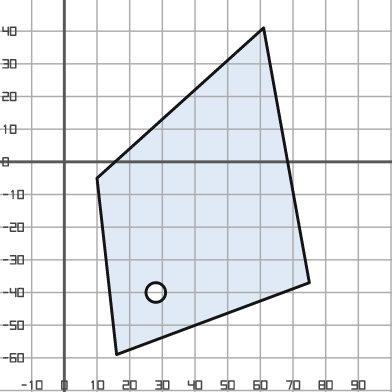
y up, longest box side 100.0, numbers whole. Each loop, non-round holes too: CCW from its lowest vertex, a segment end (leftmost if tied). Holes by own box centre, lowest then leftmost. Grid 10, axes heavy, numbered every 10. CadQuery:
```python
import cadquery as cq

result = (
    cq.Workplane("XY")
    .moveTo(16.0, -59.0)
    .lineTo(75.0, -37.0)
    .lineTo(61.0, 41.0)
    .lineTo(10.0, -5.0)
    .close()
    .moveTo(28.0, -40.0)
    .circle(3.0)
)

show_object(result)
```